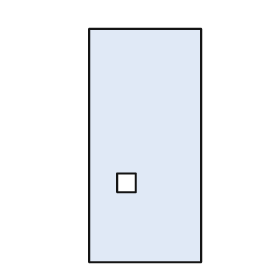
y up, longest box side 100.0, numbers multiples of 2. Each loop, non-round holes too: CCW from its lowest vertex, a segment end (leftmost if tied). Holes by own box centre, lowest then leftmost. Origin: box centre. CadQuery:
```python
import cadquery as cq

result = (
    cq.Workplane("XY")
    .moveTo(-24.0, -50.0)
    .lineTo(24.0, -50.0)
    .lineTo(24.0, 50.0)
    .lineTo(-24.0, 50.0)
    .close()
    .moveTo(-12.0, -20.0)
    .lineTo(-4.0, -20.0)
    .lineTo(-4.0, -12.0)
    .lineTo(-12.0, -12.0)
    .close()
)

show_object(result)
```